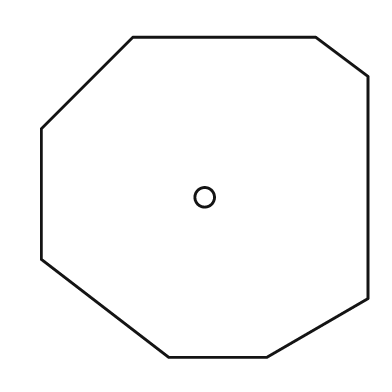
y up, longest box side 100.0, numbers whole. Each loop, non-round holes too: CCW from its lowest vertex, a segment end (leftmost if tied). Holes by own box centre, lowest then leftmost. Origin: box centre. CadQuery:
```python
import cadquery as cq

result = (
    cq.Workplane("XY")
    .moveTo(-11.0, -49.0)
    .lineTo(19.0, -49.0)
    .lineTo(50.0, -31.0)
    .lineTo(50.0, 37.0)
    .lineTo(34.0, 49.0)
    .lineTo(-22.0, 49.0)
    .lineTo(-50.0, 21.0)
    .lineTo(-50.0, -19.0)
    .close()
    .moveTo(0.0, 0.0)
    .circle(3.0)
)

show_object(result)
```